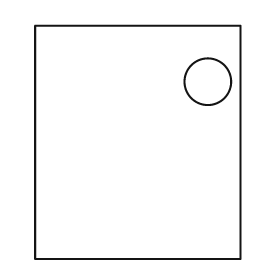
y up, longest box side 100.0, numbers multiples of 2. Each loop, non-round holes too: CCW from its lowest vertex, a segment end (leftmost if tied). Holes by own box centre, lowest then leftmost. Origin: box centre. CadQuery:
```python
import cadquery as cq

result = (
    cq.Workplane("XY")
    .moveTo(-44.0, -50.0)
    .lineTo(44.0, -50.0)
    .lineTo(44.0, 50.0)
    .lineTo(-44.0, 50.0)
    .close()
    .moveTo(30.0, 26.0)
    .circle(10.0)
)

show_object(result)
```